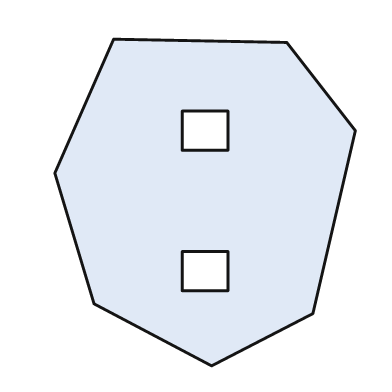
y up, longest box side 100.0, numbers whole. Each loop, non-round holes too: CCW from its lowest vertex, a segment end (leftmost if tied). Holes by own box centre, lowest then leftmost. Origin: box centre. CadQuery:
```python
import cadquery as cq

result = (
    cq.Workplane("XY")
    .moveTo(2.0, -50.0)
    .lineTo(33.0, -34.0)
    .lineTo(46.0, 22.0)
    .lineTo(25.0, 49.0)
    .lineTo(-28.0, 50.0)
    .lineTo(-46.0, 9.0)
    .lineTo(-34.0, -31.0)
    .close()
    .moveTo(-7.0, -27.0)
    .lineTo(7.0, -27.0)
    .lineTo(7.0, -15.0)
    .lineTo(-7.0, -15.0)
    .close()
    .moveTo(-7.0, 16.0)
    .lineTo(7.0, 16.0)
    .lineTo(7.0, 28.0)
    .lineTo(-7.0, 28.0)
    .close()
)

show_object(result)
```